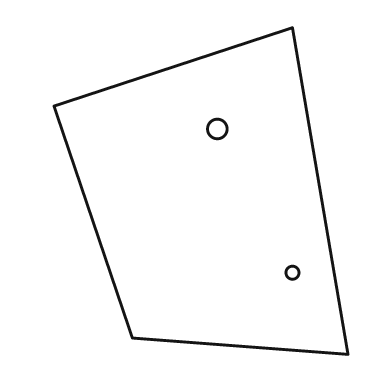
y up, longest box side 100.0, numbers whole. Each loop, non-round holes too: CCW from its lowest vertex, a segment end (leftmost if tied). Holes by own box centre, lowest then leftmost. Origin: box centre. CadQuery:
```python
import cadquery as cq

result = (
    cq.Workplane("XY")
    .moveTo(45.0, -50.0)
    .lineTo(28.0, 50.0)
    .lineTo(-45.0, 26.0)
    .lineTo(-21.0, -45.0)
    .close()
    .moveTo(28.0, -25.0)
    .circle(2.0)
    .moveTo(5.0, 19.0)
    .circle(3.0)
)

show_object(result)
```